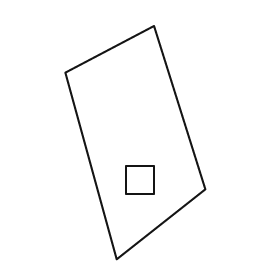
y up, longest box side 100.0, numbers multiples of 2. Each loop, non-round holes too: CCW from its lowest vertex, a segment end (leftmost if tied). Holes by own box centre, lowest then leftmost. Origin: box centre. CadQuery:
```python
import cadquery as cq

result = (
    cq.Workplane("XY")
    .moveTo(-8.0, -50.0)
    .lineTo(30.0, -20.0)
    .lineTo(8.0, 50.0)
    .lineTo(-30.0, 30.0)
    .close()
    .moveTo(-4.0, -22.0)
    .lineTo(8.0, -22.0)
    .lineTo(8.0, -10.0)
    .lineTo(-4.0, -10.0)
    .close()
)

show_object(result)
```